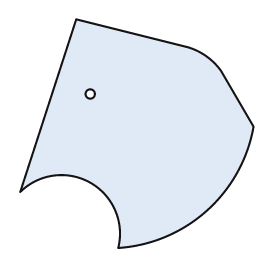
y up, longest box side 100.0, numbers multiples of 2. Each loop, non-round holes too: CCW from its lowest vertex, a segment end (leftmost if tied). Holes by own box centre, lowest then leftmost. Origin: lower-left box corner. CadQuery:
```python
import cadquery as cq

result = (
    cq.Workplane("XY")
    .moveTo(42.0, 0.0)
    .threePointArc((80.0, 16.0), (100.0, 52.0))
    .lineTo(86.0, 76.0)
    .threePointArc((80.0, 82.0), (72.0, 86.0))
    .lineTo(24.0, 98.0)
    .lineTo(0.0, 24.0)
    .threePointArc((30.0, 28.0), (42.0, 0.0))
    .close()
    .moveTo(30.0, 66.0)
    .circle(2.0)
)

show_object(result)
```